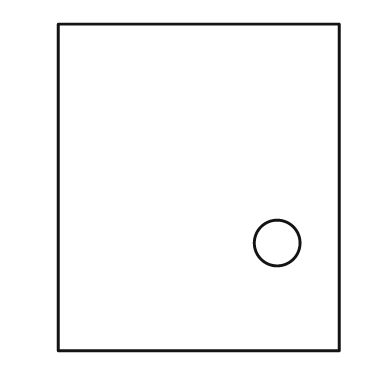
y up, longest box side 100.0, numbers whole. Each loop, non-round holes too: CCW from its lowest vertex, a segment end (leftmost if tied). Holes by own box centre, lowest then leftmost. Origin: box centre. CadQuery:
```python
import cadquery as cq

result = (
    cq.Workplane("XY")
    .moveTo(-43.0, -50.0)
    .lineTo(43.0, -50.0)
    .lineTo(43.0, 50.0)
    .lineTo(-43.0, 50.0)
    .close()
    .moveTo(24.0, -17.0)
    .circle(7.0)
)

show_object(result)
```